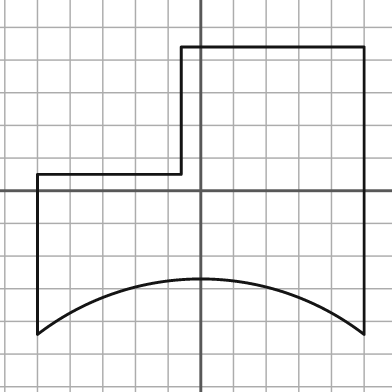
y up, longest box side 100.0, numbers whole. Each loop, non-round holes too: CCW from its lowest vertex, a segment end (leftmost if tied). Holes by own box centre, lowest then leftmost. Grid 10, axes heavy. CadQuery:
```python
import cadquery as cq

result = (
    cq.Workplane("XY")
    .moveTo(-50.0, -44.0)
    .threePointArc((0.0, -27.0), (50.0, -44.0))
    .lineTo(50.0, 44.0)
    .lineTo(-6.0, 44.0)
    .lineTo(-6.0, 5.0)
    .lineTo(-50.0, 5.0)
    .close()
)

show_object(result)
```